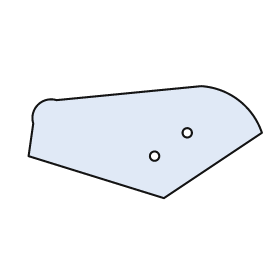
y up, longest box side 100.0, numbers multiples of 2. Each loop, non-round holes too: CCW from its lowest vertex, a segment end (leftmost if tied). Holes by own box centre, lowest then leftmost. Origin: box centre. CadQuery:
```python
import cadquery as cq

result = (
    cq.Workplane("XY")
    .moveTo(8.0, -24.0)
    .lineTo(50.0, 4.0)
    .threePointArc((40.0, 18.0), (24.0, 24.0))
    .lineTo(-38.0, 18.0)
    .threePointArc((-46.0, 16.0), (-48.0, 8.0))
    .lineTo(-50.0, -6.0)
    .close()
    .moveTo(4.0, -6.0)
    .circle(2.0)
    .moveTo(18.0, 4.0)
    .circle(2.0)
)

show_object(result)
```